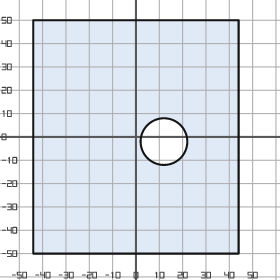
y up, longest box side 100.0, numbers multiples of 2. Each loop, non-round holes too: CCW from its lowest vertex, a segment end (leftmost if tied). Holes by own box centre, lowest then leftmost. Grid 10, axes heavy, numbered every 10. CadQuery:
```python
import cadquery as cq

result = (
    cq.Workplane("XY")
    .moveTo(-44.0, -50.0)
    .lineTo(44.0, -50.0)
    .lineTo(44.0, 50.0)
    .lineTo(-44.0, 50.0)
    .close()
    .moveTo(12.0, -2.0)
    .circle(10.0)
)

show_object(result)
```